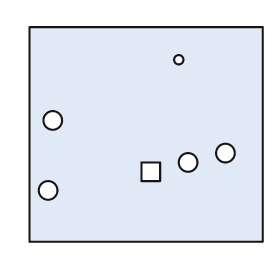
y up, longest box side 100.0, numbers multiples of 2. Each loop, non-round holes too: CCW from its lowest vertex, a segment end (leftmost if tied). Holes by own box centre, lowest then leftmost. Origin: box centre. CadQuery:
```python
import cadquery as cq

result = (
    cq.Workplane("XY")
    .moveTo(-50.0, -46.0)
    .lineTo(50.0, -46.0)
    .lineTo(50.0, 46.0)
    .lineTo(-50.0, 46.0)
    .close()
    .moveTo(-42.0, -24.0)
    .circle(4.0)
    .moveTo(-2.0, -20.0)
    .lineTo(6.0, -20.0)
    .lineTo(6.0, -12.0)
    .lineTo(-2.0, -12.0)
    .close()
    .moveTo(18.0, -12.0)
    .circle(4.0)
    .moveTo(34.0, -8.0)
    .circle(4.0)
    .moveTo(-40.0, 6.0)
    .circle(4.0)
    .moveTo(14.0, 32.0)
    .circle(2.0)
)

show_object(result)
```